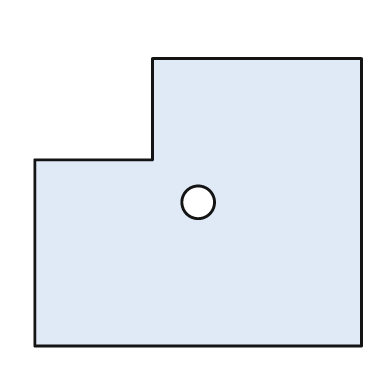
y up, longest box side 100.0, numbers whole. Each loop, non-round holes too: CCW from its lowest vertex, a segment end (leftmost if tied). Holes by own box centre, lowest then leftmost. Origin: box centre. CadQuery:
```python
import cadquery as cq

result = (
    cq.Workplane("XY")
    .moveTo(-50.0, -44.0)
    .lineTo(50.0, -44.0)
    .lineTo(50.0, 44.0)
    .lineTo(-14.0, 44.0)
    .lineTo(-14.0, 13.0)
    .lineTo(-50.0, 13.0)
    .close()
    .moveTo(0.0, 0.0)
    .circle(5.0)
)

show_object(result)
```